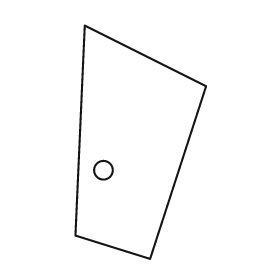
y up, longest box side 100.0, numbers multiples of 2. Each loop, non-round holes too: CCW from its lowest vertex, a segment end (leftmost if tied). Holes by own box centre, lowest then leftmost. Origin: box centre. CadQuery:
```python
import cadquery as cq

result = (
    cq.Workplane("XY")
    .moveTo(4.0, -50.0)
    .lineTo(28.0, 24.0)
    .lineTo(-24.0, 50.0)
    .lineTo(-28.0, -40.0)
    .close()
    .moveTo(-16.0, -12.0)
    .circle(4.0)
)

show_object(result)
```